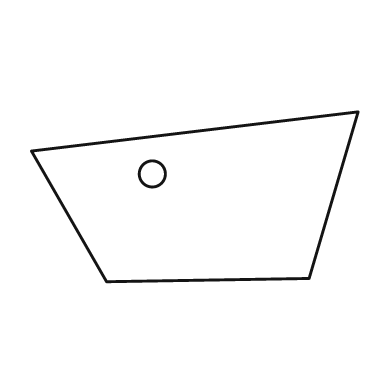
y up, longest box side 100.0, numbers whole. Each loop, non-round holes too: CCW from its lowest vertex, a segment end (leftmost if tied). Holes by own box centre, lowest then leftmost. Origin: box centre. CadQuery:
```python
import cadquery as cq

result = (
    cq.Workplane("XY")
    .moveTo(-27.0, -26.0)
    .lineTo(35.0, -25.0)
    .lineTo(50.0, 26.0)
    .lineTo(-50.0, 14.0)
    .close()
    .moveTo(-13.0, 7.0)
    .circle(4.0)
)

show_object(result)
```